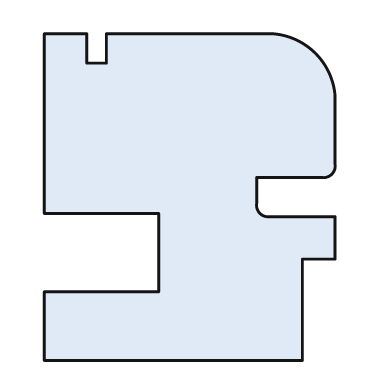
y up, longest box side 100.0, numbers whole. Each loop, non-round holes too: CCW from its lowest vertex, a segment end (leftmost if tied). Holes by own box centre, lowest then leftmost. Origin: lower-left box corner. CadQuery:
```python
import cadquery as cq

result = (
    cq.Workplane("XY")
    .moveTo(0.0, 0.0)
    .lineTo(79.0, 0.0)
    .lineTo(79.0, 31.0)
    .lineTo(89.0, 31.0)
    .lineTo(89.0, 44.0)
    .lineTo(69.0, 44.0)
    .threePointArc((66.0, 45.0), (65.0, 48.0))
    .lineTo(65.0, 56.0)
    .lineTo(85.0, 56.0)
    .threePointArc((88.0, 57.0), (89.0, 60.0))
    .lineTo(89.0, 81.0)
    .threePointArc((83.0, 94.0), (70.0, 100.0))
    .lineTo(19.0, 100.0)
    .lineTo(19.0, 91.0)
    .lineTo(13.0, 91.0)
    .lineTo(13.0, 100.0)
    .lineTo(0.0, 100.0)
    .lineTo(0.0, 45.0)
    .lineTo(35.0, 45.0)
    .lineTo(35.0, 21.0)
    .lineTo(0.0, 21.0)
    .close()
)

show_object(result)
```